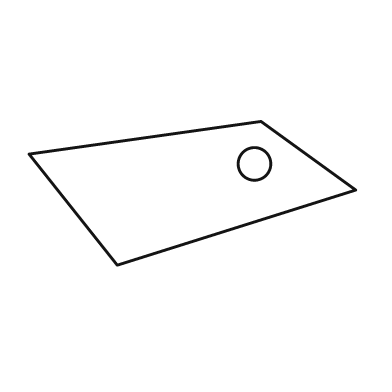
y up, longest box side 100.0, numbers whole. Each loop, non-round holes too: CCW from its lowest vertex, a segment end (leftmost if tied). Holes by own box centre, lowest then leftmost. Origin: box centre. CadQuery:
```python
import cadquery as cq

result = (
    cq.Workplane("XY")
    .moveTo(-23.0, -22.0)
    .lineTo(50.0, 1.0)
    .lineTo(21.0, 22.0)
    .lineTo(-50.0, 12.0)
    .close()
    .moveTo(19.0, 9.0)
    .circle(5.0)
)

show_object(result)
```